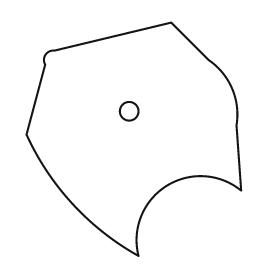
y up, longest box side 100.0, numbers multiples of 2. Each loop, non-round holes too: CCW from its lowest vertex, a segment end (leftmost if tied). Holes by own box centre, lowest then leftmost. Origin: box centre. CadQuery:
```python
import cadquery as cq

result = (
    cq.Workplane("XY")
    .moveTo(2.0, -50.0)
    .threePointArc((14.0, -20.0), (46.0, -22.0))
    .lineTo(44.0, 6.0)
    .threePointArc((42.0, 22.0), (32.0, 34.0))
    .lineTo(16.0, 50.0)
    .lineTo(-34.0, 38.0)
    .threePointArc((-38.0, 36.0), (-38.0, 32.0))
    .lineTo(-46.0, 2.0)
    .threePointArc((-26.0, -28.0), (2.0, -50.0))
    .close()
    .moveTo(-2.0, 12.0)
    .circle(4.0)
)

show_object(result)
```